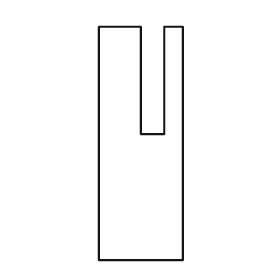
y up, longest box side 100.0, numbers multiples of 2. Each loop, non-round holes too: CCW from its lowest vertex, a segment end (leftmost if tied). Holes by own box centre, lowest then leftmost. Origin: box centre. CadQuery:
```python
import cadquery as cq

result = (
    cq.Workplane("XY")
    .moveTo(-18.0, -50.0)
    .lineTo(18.0, -50.0)
    .lineTo(18.0, 50.0)
    .lineTo(10.0, 50.0)
    .lineTo(10.0, 4.0)
    .lineTo(0.0, 4.0)
    .lineTo(0.0, 50.0)
    .lineTo(-18.0, 50.0)
    .close()
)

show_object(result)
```